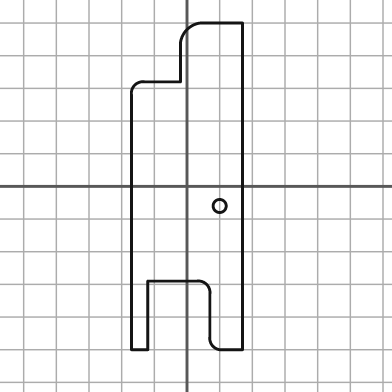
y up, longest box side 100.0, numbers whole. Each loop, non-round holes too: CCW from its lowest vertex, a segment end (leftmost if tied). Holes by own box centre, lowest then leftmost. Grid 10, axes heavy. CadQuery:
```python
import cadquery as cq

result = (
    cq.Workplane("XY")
    .moveTo(-17.0, -50.0)
    .lineTo(-12.0, -50.0)
    .lineTo(-12.0, -29.0)
    .lineTo(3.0, -29.0)
    .threePointArc((6.0, -30.0), (7.0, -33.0))
    .lineTo(7.0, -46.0)
    .threePointArc((8.0, -49.0), (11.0, -50.0))
    .lineTo(17.0, -50.0)
    .lineTo(17.0, 50.0)
    .lineTo(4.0, 50.0)
    .threePointArc((0.0, 48.0), (-2.0, 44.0))
    .lineTo(-2.0, 32.0)
    .lineTo(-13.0, 32.0)
    .threePointArc((-16.0, 31.0), (-17.0, 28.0))
    .close()
    .moveTo(10.0, -6.0)
    .circle(2.0)
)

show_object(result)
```